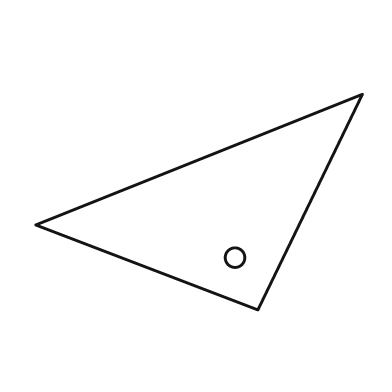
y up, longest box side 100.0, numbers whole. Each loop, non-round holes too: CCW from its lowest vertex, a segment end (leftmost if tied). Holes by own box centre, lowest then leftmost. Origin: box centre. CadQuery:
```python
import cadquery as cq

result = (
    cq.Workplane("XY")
    .moveTo(18.0, -33.0)
    .lineTo(50.0, 33.0)
    .lineTo(-50.0, -7.0)
    .close()
    .moveTo(11.0, -17.0)
    .circle(3.0)
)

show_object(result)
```